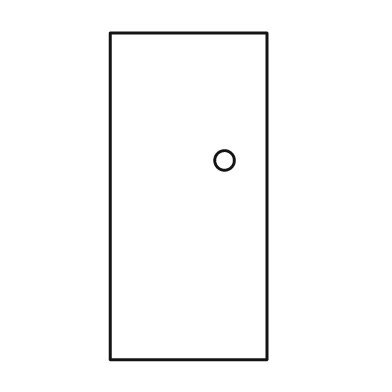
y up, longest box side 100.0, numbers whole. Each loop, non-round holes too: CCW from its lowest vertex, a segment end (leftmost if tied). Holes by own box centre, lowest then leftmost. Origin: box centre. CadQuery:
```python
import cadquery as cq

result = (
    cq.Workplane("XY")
    .moveTo(-24.0, -50.0)
    .lineTo(24.0, -50.0)
    .lineTo(24.0, 50.0)
    .lineTo(-24.0, 50.0)
    .close()
    .moveTo(11.0, 11.0)
    .circle(3.0)
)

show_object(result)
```